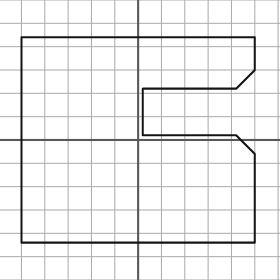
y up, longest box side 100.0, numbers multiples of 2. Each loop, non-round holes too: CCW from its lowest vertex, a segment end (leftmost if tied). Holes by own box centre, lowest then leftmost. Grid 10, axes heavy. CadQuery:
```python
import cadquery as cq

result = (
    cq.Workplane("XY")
    .moveTo(-50.0, -44.0)
    .lineTo(50.0, -44.0)
    .lineTo(50.0, -6.0)
    .lineTo(42.0, 2.0)
    .lineTo(2.0, 2.0)
    .lineTo(2.0, 22.0)
    .lineTo(42.0, 22.0)
    .lineTo(50.0, 30.0)
    .lineTo(50.0, 44.0)
    .lineTo(-50.0, 44.0)
    .close()
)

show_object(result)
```